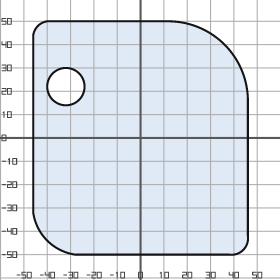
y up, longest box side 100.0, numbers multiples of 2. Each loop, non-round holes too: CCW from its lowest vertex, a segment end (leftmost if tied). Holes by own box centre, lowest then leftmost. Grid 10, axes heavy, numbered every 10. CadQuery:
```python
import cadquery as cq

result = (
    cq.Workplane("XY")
    .moveTo(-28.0, -50.0)
    .lineTo(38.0, -50.0)
    .threePointArc((44.0, -48.0), (46.0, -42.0))
    .lineTo(46.0, 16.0)
    .threePointArc((36.0, 40.0), (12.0, 50.0))
    .lineTo(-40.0, 50.0)
    .threePointArc((-44.0, 48.0), (-46.0, 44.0))
    .lineTo(-46.0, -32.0)
    .threePointArc((-40.0, -44.0), (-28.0, -50.0))
    .close()
    .moveTo(-32.0, 22.0)
    .circle(8.0)
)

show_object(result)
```